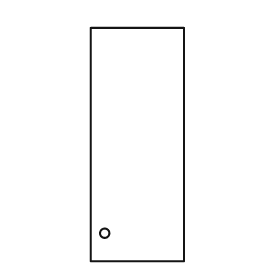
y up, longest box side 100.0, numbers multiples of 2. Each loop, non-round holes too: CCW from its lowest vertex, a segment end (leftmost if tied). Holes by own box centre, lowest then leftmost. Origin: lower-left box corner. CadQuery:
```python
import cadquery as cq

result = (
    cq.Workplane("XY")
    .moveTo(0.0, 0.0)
    .lineTo(40.0, 0.0)
    .lineTo(40.0, 100.0)
    .lineTo(0.0, 100.0)
    .close()
    .moveTo(6.0, 12.0)
    .circle(2.0)
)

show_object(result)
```